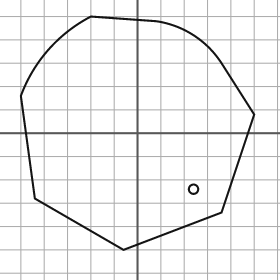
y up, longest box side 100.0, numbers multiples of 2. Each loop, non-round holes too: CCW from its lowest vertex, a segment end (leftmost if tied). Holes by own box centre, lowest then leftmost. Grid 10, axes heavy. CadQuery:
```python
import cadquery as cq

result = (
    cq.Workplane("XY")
    .moveTo(-6.0, -50.0)
    .lineTo(36.0, -34.0)
    .lineTo(50.0, 8.0)
    .lineTo(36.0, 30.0)
    .threePointArc((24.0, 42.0), (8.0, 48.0))
    .lineTo(-20.0, 50.0)
    .threePointArc((-38.0, 36.0), (-50.0, 16.0))
    .lineTo(-44.0, -28.0)
    .close()
    .moveTo(24.0, -24.0)
    .circle(2.0)
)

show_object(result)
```